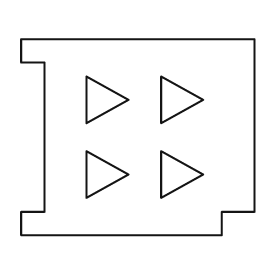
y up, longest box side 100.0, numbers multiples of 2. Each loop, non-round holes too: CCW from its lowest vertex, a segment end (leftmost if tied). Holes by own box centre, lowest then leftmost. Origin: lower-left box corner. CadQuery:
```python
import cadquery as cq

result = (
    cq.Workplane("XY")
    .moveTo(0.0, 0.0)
    .lineTo(86.0, 0.0)
    .lineTo(86.0, 10.0)
    .lineTo(100.0, 10.0)
    .lineTo(100.0, 84.0)
    .lineTo(0.0, 84.0)
    .lineTo(0.0, 74.0)
    .lineTo(10.0, 74.0)
    .lineTo(10.0, 10.0)
    .lineTo(0.0, 10.0)
    .close()
    .moveTo(28.0, 16.0)
    .lineTo(46.0, 26.0)
    .lineTo(28.0, 36.0)
    .close()
    .moveTo(60.0, 16.0)
    .lineTo(78.0, 26.0)
    .lineTo(60.0, 36.0)
    .close()
    .moveTo(28.0, 48.0)
    .lineTo(46.0, 58.0)
    .lineTo(28.0, 68.0)
    .close()
    .moveTo(60.0, 48.0)
    .lineTo(78.0, 58.0)
    .lineTo(60.0, 68.0)
    .close()
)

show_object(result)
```